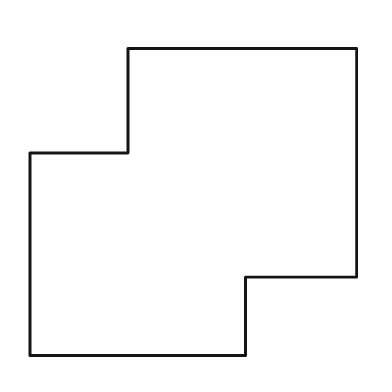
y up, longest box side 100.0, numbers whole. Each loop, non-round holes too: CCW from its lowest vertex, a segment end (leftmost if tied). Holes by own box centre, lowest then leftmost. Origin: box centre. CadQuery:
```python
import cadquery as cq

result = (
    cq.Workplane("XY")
    .moveTo(-50.0, -47.0)
    .lineTo(16.0, -47.0)
    .lineTo(16.0, -23.0)
    .lineTo(50.0, -23.0)
    .lineTo(50.0, 47.0)
    .lineTo(-20.0, 47.0)
    .lineTo(-20.0, 15.0)
    .lineTo(-50.0, 15.0)
    .close()
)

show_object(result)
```